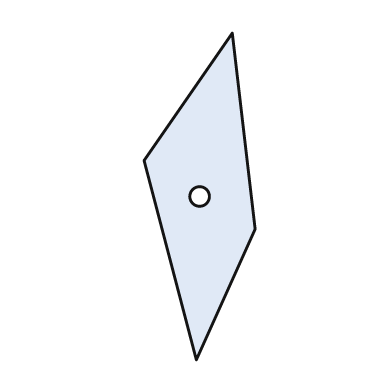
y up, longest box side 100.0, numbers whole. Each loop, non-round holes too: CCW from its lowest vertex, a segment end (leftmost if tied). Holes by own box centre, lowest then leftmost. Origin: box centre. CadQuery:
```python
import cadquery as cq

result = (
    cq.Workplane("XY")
    .moveTo(-1.0, -50.0)
    .lineTo(17.0, -10.0)
    .lineTo(10.0, 50.0)
    .lineTo(-17.0, 11.0)
    .close()
    .moveTo(0.0, 0.0)
    .circle(3.0)
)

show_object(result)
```